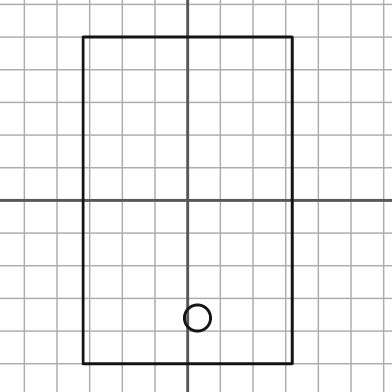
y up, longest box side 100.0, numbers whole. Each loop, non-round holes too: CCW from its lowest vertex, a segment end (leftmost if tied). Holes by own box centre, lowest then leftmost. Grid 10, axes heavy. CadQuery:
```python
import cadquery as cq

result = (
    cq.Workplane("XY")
    .moveTo(-32.0, -50.0)
    .lineTo(32.0, -50.0)
    .lineTo(32.0, 50.0)
    .lineTo(-32.0, 50.0)
    .close()
    .moveTo(3.0, -36.0)
    .circle(4.0)
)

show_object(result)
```